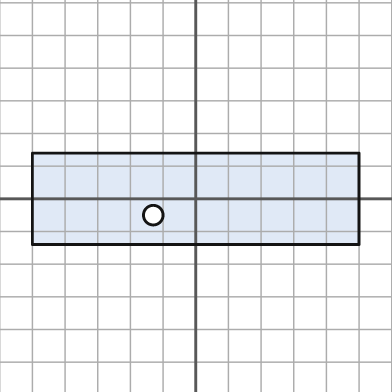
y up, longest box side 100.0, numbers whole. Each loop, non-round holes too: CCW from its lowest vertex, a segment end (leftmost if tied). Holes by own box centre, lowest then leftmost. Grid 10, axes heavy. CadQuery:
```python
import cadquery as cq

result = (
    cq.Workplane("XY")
    .moveTo(-50.0, -14.0)
    .lineTo(50.0, -14.0)
    .lineTo(50.0, 14.0)
    .lineTo(-50.0, 14.0)
    .close()
    .moveTo(-13.0, -5.0)
    .circle(3.0)
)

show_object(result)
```